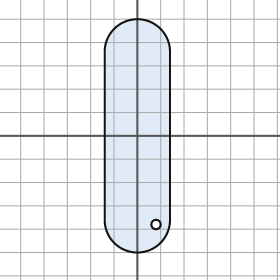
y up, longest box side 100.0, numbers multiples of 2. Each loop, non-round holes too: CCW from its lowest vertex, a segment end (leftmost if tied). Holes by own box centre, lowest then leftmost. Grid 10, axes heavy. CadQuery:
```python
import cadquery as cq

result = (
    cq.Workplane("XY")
    .moveTo(-14.0, -36.0)
    .threePointArc((0.0, -50.0), (14.0, -36.0))
    .lineTo(14.0, 36.0)
    .threePointArc((0.0, 50.0), (-14.0, 36.0))
    .close()
    .moveTo(8.0, -38.0)
    .circle(2.0)
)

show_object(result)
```